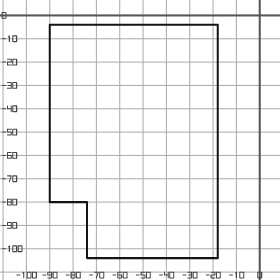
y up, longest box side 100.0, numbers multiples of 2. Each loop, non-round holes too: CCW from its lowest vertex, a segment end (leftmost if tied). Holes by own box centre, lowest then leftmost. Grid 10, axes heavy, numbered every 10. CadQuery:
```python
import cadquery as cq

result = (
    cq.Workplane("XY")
    .moveTo(-74.0, -104.0)
    .lineTo(-18.0, -104.0)
    .lineTo(-18.0, -4.0)
    .lineTo(-90.0, -4.0)
    .lineTo(-90.0, -80.0)
    .lineTo(-74.0, -80.0)
    .close()
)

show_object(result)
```